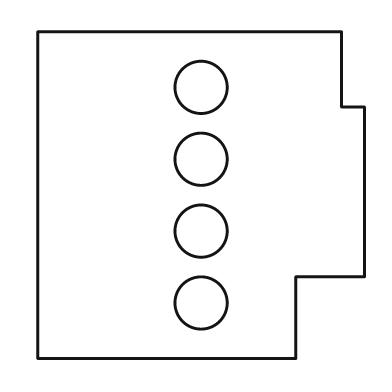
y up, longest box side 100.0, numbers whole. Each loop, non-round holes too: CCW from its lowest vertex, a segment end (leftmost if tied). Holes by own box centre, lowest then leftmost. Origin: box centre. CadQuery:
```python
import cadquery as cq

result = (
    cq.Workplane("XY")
    .moveTo(-50.0, -50.0)
    .lineTo(29.0, -50.0)
    .lineTo(29.0, -25.0)
    .lineTo(50.0, -25.0)
    .lineTo(50.0, 27.0)
    .lineTo(43.0, 27.0)
    .lineTo(43.0, 50.0)
    .lineTo(-50.0, 50.0)
    .close()
    .moveTo(0.0, -33.0)
    .circle(8.0)
    .moveTo(0.0, -11.0)
    .circle(8.0)
    .moveTo(0.0, 11.0)
    .circle(8.0)
    .moveTo(0.0, 33.0)
    .circle(8.0)
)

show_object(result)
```